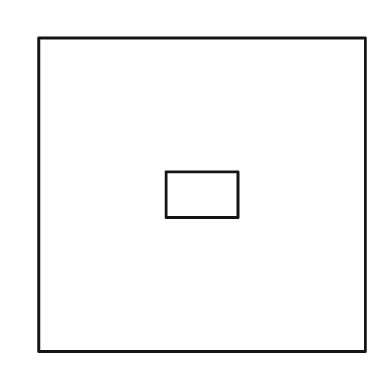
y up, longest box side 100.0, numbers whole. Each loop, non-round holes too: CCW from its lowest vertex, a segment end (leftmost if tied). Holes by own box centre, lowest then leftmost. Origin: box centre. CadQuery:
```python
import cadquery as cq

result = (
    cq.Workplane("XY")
    .moveTo(-50.0, -48.0)
    .lineTo(50.0, -48.0)
    .lineTo(50.0, 48.0)
    .lineTo(-50.0, 48.0)
    .close()
    .moveTo(-11.0, -7.0)
    .lineTo(11.0, -7.0)
    .lineTo(11.0, 7.0)
    .lineTo(-11.0, 7.0)
    .close()
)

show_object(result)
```